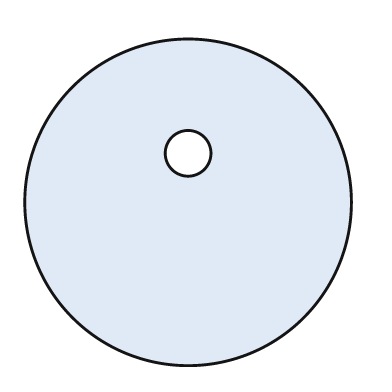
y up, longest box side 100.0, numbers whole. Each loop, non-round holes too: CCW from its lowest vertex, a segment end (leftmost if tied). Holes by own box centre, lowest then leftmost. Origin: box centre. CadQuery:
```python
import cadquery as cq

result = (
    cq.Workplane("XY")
    .moveTo(0.0, 0.0)
    .circle(50.0)
    .moveTo(0.0, 15.0)
    .circle(7.0)
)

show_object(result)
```